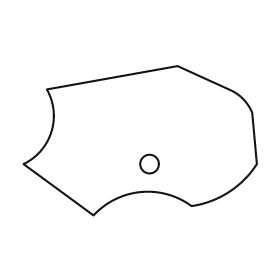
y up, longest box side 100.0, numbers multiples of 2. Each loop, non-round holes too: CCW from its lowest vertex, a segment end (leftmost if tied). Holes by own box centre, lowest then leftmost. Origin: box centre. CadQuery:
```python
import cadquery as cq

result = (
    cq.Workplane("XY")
    .moveTo(-20.0, -32.0)
    .threePointArc((0.0, -22.0), (22.0, -28.0))
    .threePointArc((38.0, -22.0), (50.0, -10.0))
    .lineTo(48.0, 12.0)
    .threePointArc((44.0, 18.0), (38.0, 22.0))
    .lineTo(16.0, 32.0)
    .lineTo(-40.0, 22.0)
    .threePointArc((-38.0, 4.0), (-50.0, -10.0))
    .close()
    .moveTo(4.0, -10.0)
    .circle(4.0)
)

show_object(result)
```